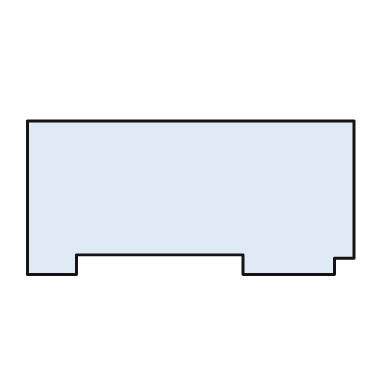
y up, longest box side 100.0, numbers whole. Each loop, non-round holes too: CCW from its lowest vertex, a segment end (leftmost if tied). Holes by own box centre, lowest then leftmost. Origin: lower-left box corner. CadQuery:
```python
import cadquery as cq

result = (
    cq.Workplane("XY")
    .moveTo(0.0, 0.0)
    .lineTo(15.0, 0.0)
    .lineTo(15.0, 6.0)
    .lineTo(66.0, 6.0)
    .lineTo(66.0, 0.0)
    .lineTo(94.0, 0.0)
    .lineTo(94.0, 5.0)
    .lineTo(100.0, 5.0)
    .lineTo(100.0, 47.0)
    .lineTo(0.0, 47.0)
    .close()
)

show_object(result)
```